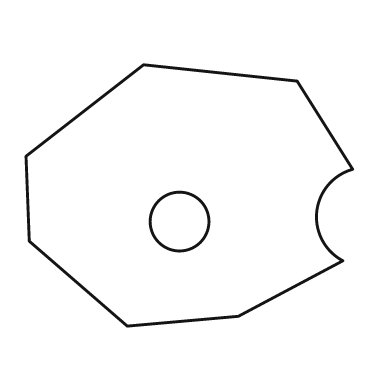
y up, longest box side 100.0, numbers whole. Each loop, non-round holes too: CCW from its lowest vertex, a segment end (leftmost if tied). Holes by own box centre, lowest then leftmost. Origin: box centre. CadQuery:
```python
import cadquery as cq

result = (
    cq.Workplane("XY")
    .moveTo(-19.0, -40.0)
    .lineTo(15.0, -37.0)
    .lineTo(47.0, -20.0)
    .threePointArc((39.0, -5.0), (50.0, 8.0))
    .lineTo(33.0, 35.0)
    .lineTo(-14.0, 40.0)
    .lineTo(-50.0, 12.0)
    .lineTo(-49.0, -14.0)
    .close()
    .moveTo(-3.0, -8.0)
    .circle(9.0)
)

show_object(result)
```